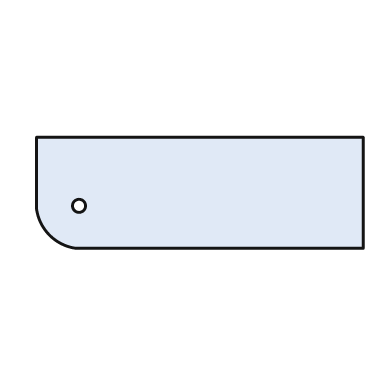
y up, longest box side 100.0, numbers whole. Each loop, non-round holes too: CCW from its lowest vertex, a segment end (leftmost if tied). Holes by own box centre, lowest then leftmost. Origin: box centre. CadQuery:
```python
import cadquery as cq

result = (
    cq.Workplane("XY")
    .moveTo(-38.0, -17.0)
    .lineTo(50.0, -17.0)
    .lineTo(50.0, 17.0)
    .lineTo(-50.0, 17.0)
    .lineTo(-50.0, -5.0)
    .threePointArc((-46.0, -13.0), (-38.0, -17.0))
    .close()
    .moveTo(-37.0, -4.0)
    .circle(2.0)
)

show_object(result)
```